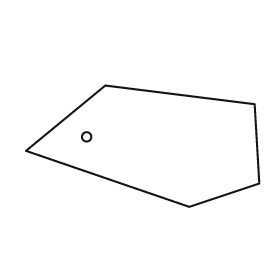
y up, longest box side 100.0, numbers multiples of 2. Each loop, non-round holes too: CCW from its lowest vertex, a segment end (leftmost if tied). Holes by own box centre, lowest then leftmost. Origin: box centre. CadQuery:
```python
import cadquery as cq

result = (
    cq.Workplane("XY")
    .moveTo(20.0, -26.0)
    .lineTo(50.0, -16.0)
    .lineTo(48.0, 18.0)
    .lineTo(-16.0, 26.0)
    .lineTo(-50.0, -2.0)
    .close()
    .moveTo(-24.0, 4.0)
    .circle(2.0)
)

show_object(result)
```